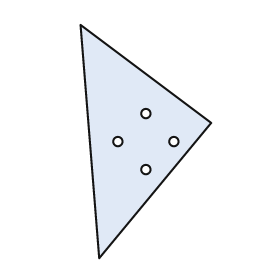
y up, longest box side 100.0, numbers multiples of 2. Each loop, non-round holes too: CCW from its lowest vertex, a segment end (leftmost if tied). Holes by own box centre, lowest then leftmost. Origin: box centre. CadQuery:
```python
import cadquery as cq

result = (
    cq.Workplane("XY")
    .moveTo(-20.0, -50.0)
    .lineTo(28.0, 8.0)
    .lineTo(-28.0, 50.0)
    .close()
    .moveTo(0.0, -12.0)
    .circle(2.0)
    .moveTo(-12.0, 0.0)
    .circle(2.0)
    .moveTo(12.0, 0.0)
    .circle(2.0)
    .moveTo(0.0, 12.0)
    .circle(2.0)
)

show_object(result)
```